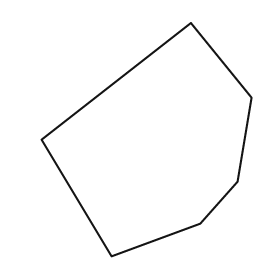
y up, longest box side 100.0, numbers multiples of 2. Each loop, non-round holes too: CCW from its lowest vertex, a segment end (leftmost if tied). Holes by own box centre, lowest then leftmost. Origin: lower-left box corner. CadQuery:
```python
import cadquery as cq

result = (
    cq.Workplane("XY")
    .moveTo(30.0, 0.0)
    .lineTo(68.0, 14.0)
    .lineTo(84.0, 32.0)
    .lineTo(90.0, 68.0)
    .lineTo(64.0, 100.0)
    .lineTo(0.0, 50.0)
    .close()
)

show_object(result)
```